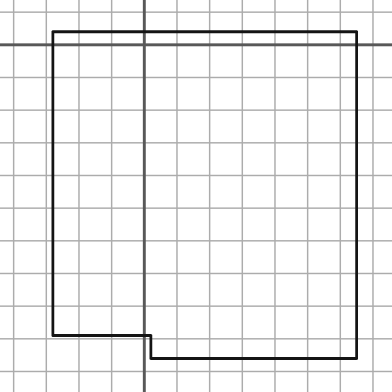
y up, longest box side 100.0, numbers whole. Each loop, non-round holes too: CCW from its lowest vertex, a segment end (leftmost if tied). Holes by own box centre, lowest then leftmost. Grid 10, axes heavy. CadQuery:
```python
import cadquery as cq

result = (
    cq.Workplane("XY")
    .moveTo(2.0, -96.0)
    .lineTo(65.0, -96.0)
    .lineTo(65.0, 4.0)
    .lineTo(-28.0, 4.0)
    .lineTo(-28.0, -89.0)
    .lineTo(2.0, -89.0)
    .close()
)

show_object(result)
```